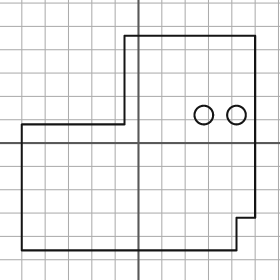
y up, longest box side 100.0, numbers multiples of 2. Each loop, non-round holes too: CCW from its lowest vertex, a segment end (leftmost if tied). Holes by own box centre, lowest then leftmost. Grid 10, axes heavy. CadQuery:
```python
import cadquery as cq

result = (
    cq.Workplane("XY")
    .moveTo(-50.0, -46.0)
    .lineTo(42.0, -46.0)
    .lineTo(42.0, -32.0)
    .lineTo(50.0, -32.0)
    .lineTo(50.0, 46.0)
    .lineTo(-6.0, 46.0)
    .lineTo(-6.0, 8.0)
    .lineTo(-50.0, 8.0)
    .close()
    .moveTo(28.0, 12.0)
    .circle(4.0)
    .moveTo(42.0, 12.0)
    .circle(4.0)
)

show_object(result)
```